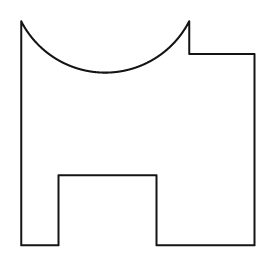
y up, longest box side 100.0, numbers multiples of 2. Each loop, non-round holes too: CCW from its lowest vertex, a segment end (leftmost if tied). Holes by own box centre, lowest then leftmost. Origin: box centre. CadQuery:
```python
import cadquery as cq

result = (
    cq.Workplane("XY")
    .moveTo(-50.0, -48.0)
    .lineTo(-34.0, -48.0)
    .lineTo(-34.0, -18.0)
    .lineTo(8.0, -18.0)
    .lineTo(8.0, -48.0)
    .lineTo(50.0, -48.0)
    .lineTo(50.0, 34.0)
    .lineTo(22.0, 34.0)
    .lineTo(22.0, 48.0)
    .threePointArc((-14.0, 26.0), (-50.0, 48.0))
    .close()
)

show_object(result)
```